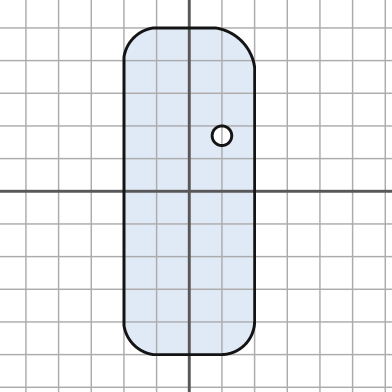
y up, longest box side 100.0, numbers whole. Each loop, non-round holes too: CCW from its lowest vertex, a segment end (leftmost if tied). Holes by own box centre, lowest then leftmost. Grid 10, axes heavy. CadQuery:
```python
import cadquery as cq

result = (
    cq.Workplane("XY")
    .moveTo(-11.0, -50.0)
    .lineTo(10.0, -50.0)
    .threePointArc((17.0, -47.0), (20.0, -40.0))
    .lineTo(20.0, 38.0)
    .threePointArc((16.0, 46.0), (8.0, 50.0))
    .lineTo(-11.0, 50.0)
    .threePointArc((-17.0, 47.0), (-20.0, 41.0))
    .lineTo(-20.0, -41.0)
    .threePointArc((-17.0, -47.0), (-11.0, -50.0))
    .close()
    .moveTo(10.0, 17.0)
    .circle(3.0)
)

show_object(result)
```